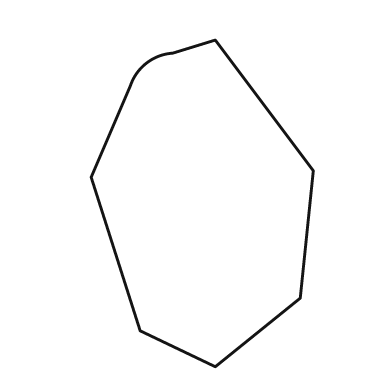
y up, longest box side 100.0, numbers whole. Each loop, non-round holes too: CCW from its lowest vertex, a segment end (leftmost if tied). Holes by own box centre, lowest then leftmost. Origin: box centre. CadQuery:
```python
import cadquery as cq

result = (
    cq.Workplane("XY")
    .moveTo(4.0, -50.0)
    .lineTo(30.0, -29.0)
    .lineTo(34.0, 10.0)
    .lineTo(4.0, 50.0)
    .lineTo(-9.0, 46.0)
    .threePointArc((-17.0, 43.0), (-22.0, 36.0))
    .lineTo(-34.0, 8.0)
    .lineTo(-19.0, -39.0)
    .close()
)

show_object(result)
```